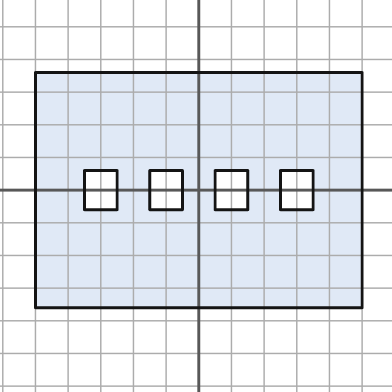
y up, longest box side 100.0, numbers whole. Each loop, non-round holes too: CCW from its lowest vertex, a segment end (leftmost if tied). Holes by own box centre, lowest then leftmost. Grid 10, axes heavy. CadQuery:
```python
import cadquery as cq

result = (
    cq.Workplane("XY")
    .moveTo(-50.0, -36.0)
    .lineTo(50.0, -36.0)
    .lineTo(50.0, 36.0)
    .lineTo(-50.0, 36.0)
    .close()
    .moveTo(-35.0, -6.0)
    .lineTo(-25.0, -6.0)
    .lineTo(-25.0, 6.0)
    .lineTo(-35.0, 6.0)
    .close()
    .moveTo(-15.0, -6.0)
    .lineTo(-5.0, -6.0)
    .lineTo(-5.0, 6.0)
    .lineTo(-15.0, 6.0)
    .close()
    .moveTo(5.0, -6.0)
    .lineTo(15.0, -6.0)
    .lineTo(15.0, 6.0)
    .lineTo(5.0, 6.0)
    .close()
    .moveTo(25.0, -6.0)
    .lineTo(35.0, -6.0)
    .lineTo(35.0, 6.0)
    .lineTo(25.0, 6.0)
    .close()
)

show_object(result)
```